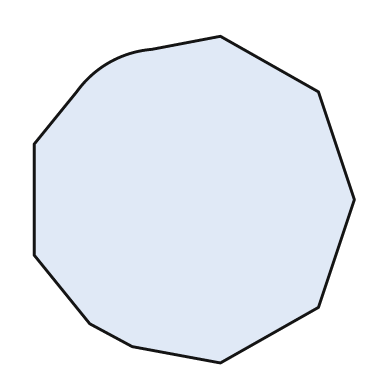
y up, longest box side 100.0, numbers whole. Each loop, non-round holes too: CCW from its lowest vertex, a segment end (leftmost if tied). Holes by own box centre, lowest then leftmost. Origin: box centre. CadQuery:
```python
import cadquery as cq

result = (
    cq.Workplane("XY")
    .moveTo(8.0, -50.0)
    .lineTo(38.0, -33.0)
    .lineTo(49.0, 0.0)
    .lineTo(38.0, 33.0)
    .lineTo(8.0, 50.0)
    .lineTo(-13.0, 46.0)
    .threePointArc((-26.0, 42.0), (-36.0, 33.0))
    .lineTo(-49.0, 17.0)
    .lineTo(-49.0, -17.0)
    .lineTo(-32.0, -38.0)
    .lineTo(-19.0, -45.0)
    .close()
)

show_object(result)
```